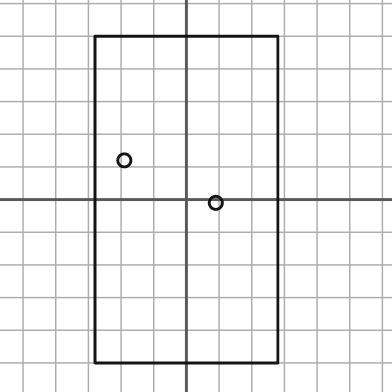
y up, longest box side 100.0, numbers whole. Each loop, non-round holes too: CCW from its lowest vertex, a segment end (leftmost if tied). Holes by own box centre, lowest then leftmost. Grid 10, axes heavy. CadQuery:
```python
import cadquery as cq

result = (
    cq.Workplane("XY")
    .moveTo(-28.0, -50.0)
    .lineTo(28.0, -50.0)
    .lineTo(28.0, 50.0)
    .lineTo(-28.0, 50.0)
    .close()
    .moveTo(9.0, -1.0)
    .circle(2.0)
    .moveTo(-19.0, 12.0)
    .circle(2.0)
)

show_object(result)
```